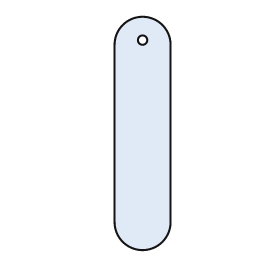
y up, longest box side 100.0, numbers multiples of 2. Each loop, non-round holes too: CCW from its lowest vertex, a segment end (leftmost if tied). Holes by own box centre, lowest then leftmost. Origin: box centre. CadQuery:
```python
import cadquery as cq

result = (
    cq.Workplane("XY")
    .moveTo(-12.0, -38.0)
    .threePointArc((0.0, -50.0), (12.0, -38.0))
    .lineTo(12.0, 38.0)
    .threePointArc((0.0, 50.0), (-12.0, 38.0))
    .close()
    .moveTo(0.0, 40.0)
    .circle(2.0)
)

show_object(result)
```